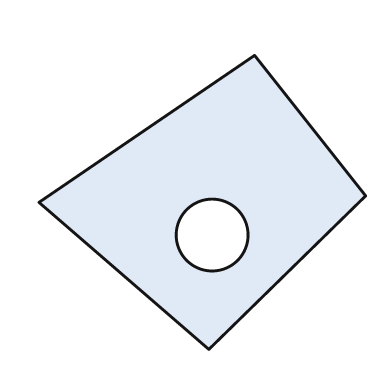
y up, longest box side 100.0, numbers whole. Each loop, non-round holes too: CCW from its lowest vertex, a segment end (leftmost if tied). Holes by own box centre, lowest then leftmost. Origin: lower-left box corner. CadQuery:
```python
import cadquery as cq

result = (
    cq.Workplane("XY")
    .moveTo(52.0, 0.0)
    .lineTo(100.0, 47.0)
    .lineTo(66.0, 90.0)
    .lineTo(0.0, 45.0)
    .close()
    .moveTo(53.0, 35.0)
    .circle(11.0)
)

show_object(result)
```